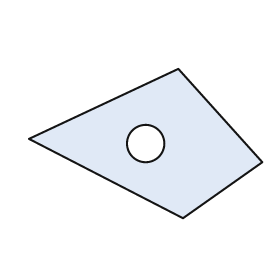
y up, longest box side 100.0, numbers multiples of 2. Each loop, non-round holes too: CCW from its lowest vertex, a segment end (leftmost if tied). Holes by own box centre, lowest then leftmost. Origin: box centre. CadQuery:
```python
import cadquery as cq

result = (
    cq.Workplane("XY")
    .moveTo(16.0, -32.0)
    .lineTo(50.0, -8.0)
    .lineTo(14.0, 32.0)
    .lineTo(-50.0, 2.0)
    .close()
    .moveTo(0.0, 0.0)
    .circle(8.0)
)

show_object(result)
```